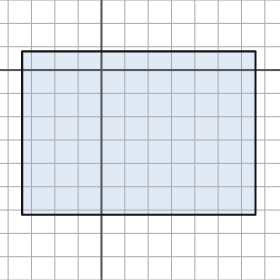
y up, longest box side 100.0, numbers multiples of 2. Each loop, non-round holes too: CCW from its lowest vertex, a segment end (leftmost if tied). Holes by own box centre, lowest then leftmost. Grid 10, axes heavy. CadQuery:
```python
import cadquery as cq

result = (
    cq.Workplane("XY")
    .moveTo(-34.0, -62.0)
    .lineTo(66.0, -62.0)
    .lineTo(66.0, 8.0)
    .lineTo(-34.0, 8.0)
    .close()
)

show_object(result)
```